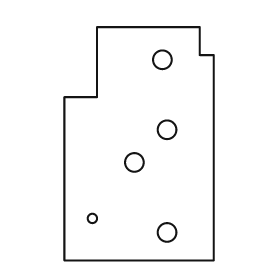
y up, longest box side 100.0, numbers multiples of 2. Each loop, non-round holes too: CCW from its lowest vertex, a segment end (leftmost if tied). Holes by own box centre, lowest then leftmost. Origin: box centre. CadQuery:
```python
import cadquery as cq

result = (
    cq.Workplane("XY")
    .moveTo(-32.0, -50.0)
    .lineTo(32.0, -50.0)
    .lineTo(32.0, 38.0)
    .lineTo(26.0, 38.0)
    .lineTo(26.0, 50.0)
    .lineTo(-18.0, 50.0)
    .lineTo(-18.0, 20.0)
    .lineTo(-32.0, 20.0)
    .close()
    .moveTo(12.0, -38.0)
    .circle(4.0)
    .moveTo(-20.0, -32.0)
    .circle(2.0)
    .moveTo(-2.0, -8.0)
    .circle(4.0)
    .moveTo(12.0, 6.0)
    .circle(4.0)
    .moveTo(10.0, 36.0)
    .circle(4.0)
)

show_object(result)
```